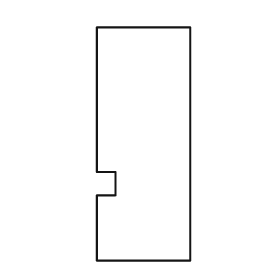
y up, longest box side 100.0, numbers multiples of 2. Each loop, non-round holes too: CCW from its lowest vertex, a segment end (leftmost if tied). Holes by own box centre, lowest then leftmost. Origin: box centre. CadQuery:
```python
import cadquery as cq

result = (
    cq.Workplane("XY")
    .moveTo(-20.0, -50.0)
    .lineTo(20.0, -50.0)
    .lineTo(20.0, 50.0)
    .lineTo(-20.0, 50.0)
    .lineTo(-20.0, -12.0)
    .lineTo(-12.0, -12.0)
    .lineTo(-12.0, -22.0)
    .lineTo(-20.0, -22.0)
    .close()
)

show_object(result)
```